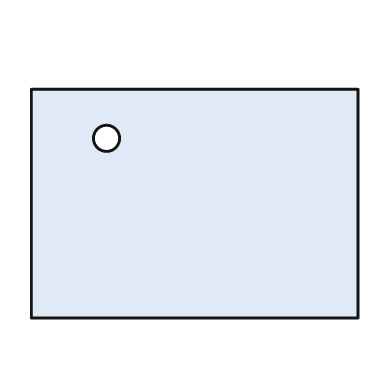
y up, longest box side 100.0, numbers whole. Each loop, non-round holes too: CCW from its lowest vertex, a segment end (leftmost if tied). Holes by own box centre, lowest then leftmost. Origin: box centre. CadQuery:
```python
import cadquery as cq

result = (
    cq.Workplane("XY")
    .moveTo(-50.0, -35.0)
    .lineTo(50.0, -35.0)
    .lineTo(50.0, 35.0)
    .lineTo(-50.0, 35.0)
    .close()
    .moveTo(-27.0, 20.0)
    .circle(4.0)
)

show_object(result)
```